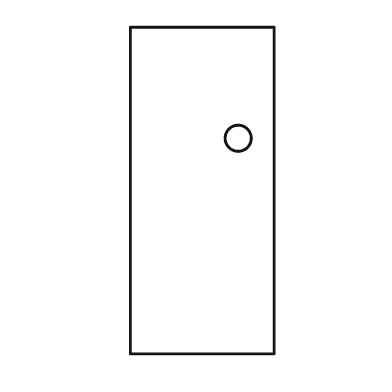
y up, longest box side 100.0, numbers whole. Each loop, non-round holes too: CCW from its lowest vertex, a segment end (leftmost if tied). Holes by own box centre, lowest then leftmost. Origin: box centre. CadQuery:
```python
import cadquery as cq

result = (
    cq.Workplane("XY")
    .moveTo(-22.0, -50.0)
    .lineTo(22.0, -50.0)
    .lineTo(22.0, 50.0)
    .lineTo(-22.0, 50.0)
    .close()
    .moveTo(11.0, 16.0)
    .circle(4.0)
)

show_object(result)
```